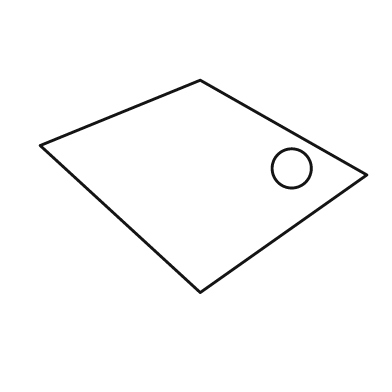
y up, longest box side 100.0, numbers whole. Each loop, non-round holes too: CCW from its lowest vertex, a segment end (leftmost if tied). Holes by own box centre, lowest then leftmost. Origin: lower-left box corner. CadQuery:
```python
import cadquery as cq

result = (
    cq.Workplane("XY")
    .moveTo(49.0, 0.0)
    .lineTo(100.0, 36.0)
    .lineTo(49.0, 65.0)
    .lineTo(0.0, 45.0)
    .close()
    .moveTo(77.0, 38.0)
    .circle(6.0)
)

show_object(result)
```